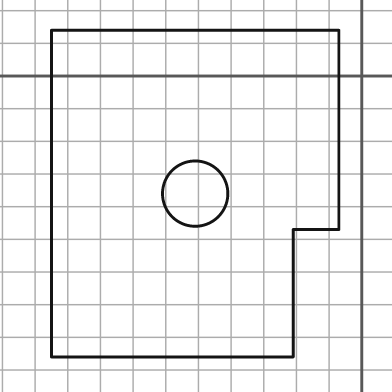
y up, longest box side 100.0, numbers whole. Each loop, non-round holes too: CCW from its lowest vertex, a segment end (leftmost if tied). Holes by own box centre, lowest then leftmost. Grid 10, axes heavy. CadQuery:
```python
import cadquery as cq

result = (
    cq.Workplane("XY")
    .moveTo(-95.0, -86.0)
    .lineTo(-21.0, -86.0)
    .lineTo(-21.0, -47.0)
    .lineTo(-7.0, -47.0)
    .lineTo(-7.0, 14.0)
    .lineTo(-95.0, 14.0)
    .close()
    .moveTo(-51.0, -36.0)
    .circle(10.0)
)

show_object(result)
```